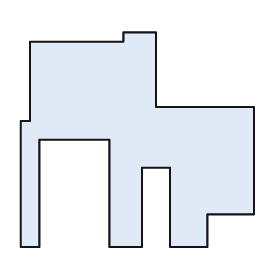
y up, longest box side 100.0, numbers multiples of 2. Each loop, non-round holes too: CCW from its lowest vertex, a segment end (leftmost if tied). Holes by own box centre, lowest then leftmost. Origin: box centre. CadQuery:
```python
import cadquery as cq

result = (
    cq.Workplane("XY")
    .moveTo(-50.0, -46.0)
    .lineTo(-42.0, -46.0)
    .lineTo(-42.0, 0.0)
    .lineTo(-12.0, 0.0)
    .lineTo(-12.0, -46.0)
    .lineTo(2.0, -46.0)
    .lineTo(2.0, -12.0)
    .lineTo(14.0, -12.0)
    .lineTo(14.0, -46.0)
    .lineTo(30.0, -46.0)
    .lineTo(30.0, -32.0)
    .lineTo(50.0, -32.0)
    .lineTo(50.0, 14.0)
    .lineTo(8.0, 14.0)
    .lineTo(8.0, 46.0)
    .lineTo(-6.0, 46.0)
    .lineTo(-6.0, 42.0)
    .lineTo(-46.0, 42.0)
    .lineTo(-46.0, 8.0)
    .lineTo(-50.0, 8.0)
    .close()
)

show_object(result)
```